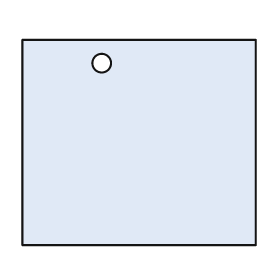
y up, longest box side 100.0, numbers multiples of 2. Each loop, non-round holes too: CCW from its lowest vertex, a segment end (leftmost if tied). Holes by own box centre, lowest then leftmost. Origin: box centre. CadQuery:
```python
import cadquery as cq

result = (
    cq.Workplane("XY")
    .moveTo(-50.0, -44.0)
    .lineTo(50.0, -44.0)
    .lineTo(50.0, 44.0)
    .lineTo(-50.0, 44.0)
    .close()
    .moveTo(-16.0, 34.0)
    .circle(4.0)
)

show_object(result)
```